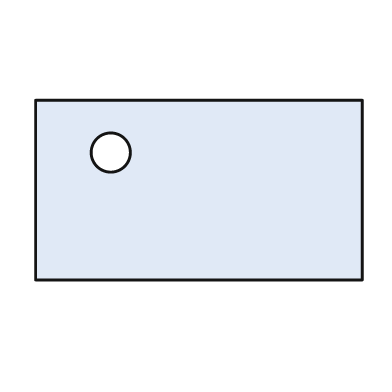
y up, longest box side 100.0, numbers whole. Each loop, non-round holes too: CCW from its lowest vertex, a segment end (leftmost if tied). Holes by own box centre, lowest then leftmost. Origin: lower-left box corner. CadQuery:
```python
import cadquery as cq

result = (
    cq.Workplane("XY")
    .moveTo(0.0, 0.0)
    .lineTo(100.0, 0.0)
    .lineTo(100.0, 55.0)
    .lineTo(0.0, 55.0)
    .close()
    .moveTo(23.0, 39.0)
    .circle(6.0)
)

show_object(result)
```